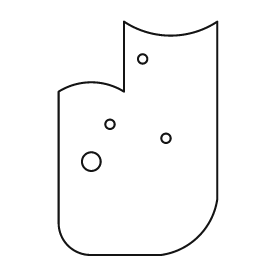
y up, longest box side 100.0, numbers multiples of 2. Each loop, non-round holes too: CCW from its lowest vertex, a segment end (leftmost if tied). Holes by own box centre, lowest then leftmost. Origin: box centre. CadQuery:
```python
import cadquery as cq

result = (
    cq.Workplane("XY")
    .moveTo(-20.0, -50.0)
    .lineTo(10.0, -50.0)
    .threePointArc((26.0, -42.0), (34.0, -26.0))
    .lineTo(34.0, 50.0)
    .threePointArc((14.0, 44.0), (-6.0, 50.0))
    .lineTo(-6.0, 20.0)
    .threePointArc((-20.0, 24.0), (-34.0, 20.0))
    .lineTo(-34.0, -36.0)
    .threePointArc((-30.0, -46.0), (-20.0, -50.0))
    .close()
    .moveTo(-20.0, -10.0)
    .circle(4.0)
    .moveTo(12.0, 0.0)
    .circle(2.0)
    .moveTo(-12.0, 6.0)
    .circle(2.0)
    .moveTo(2.0, 34.0)
    .circle(2.0)
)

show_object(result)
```